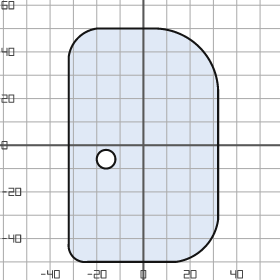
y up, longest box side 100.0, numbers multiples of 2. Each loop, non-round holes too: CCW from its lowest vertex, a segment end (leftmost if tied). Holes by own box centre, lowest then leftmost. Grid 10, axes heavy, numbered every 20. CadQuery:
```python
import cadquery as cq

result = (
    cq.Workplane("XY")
    .moveTo(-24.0, -50.0)
    .lineTo(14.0, -50.0)
    .threePointArc((26.0, -44.0), (32.0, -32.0))
    .lineTo(32.0, 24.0)
    .threePointArc((24.0, 42.0), (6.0, 50.0))
    .lineTo(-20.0, 50.0)
    .threePointArc((-28.0, 46.0), (-32.0, 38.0))
    .lineTo(-32.0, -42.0)
    .threePointArc((-30.0, -48.0), (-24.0, -50.0))
    .close()
    .moveTo(-16.0, -6.0)
    .circle(4.0)
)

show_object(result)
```